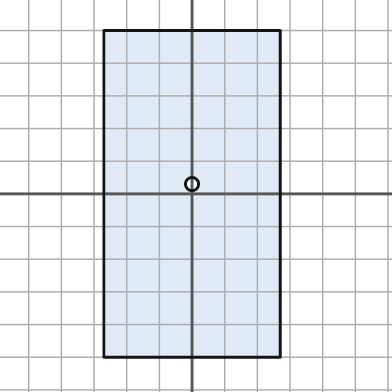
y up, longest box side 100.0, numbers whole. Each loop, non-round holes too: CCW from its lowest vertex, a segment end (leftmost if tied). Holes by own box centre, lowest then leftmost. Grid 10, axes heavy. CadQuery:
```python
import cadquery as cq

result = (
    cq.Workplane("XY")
    .moveTo(-27.0, -50.0)
    .lineTo(27.0, -50.0)
    .lineTo(27.0, 50.0)
    .lineTo(-27.0, 50.0)
    .close()
    .moveTo(0.0, 3.0)
    .circle(2.0)
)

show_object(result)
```